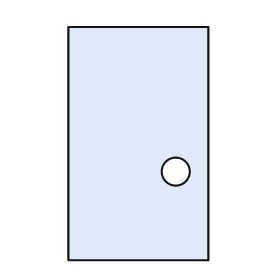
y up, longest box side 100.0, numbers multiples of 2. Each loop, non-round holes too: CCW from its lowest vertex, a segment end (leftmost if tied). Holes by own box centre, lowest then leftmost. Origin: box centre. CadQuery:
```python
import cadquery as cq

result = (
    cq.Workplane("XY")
    .moveTo(-30.0, -50.0)
    .lineTo(30.0, -50.0)
    .lineTo(30.0, 50.0)
    .lineTo(-30.0, 50.0)
    .close()
    .moveTo(16.0, -12.0)
    .circle(6.0)
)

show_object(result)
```